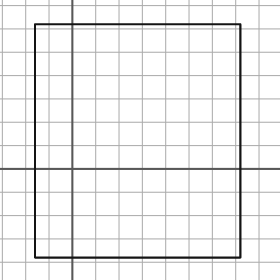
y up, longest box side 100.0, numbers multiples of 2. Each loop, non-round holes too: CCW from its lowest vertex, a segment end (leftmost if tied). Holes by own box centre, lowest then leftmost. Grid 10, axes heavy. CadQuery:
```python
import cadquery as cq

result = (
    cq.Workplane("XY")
    .moveTo(-16.0, -38.0)
    .lineTo(72.0, -38.0)
    .lineTo(72.0, 62.0)
    .lineTo(-16.0, 62.0)
    .close()
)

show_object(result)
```